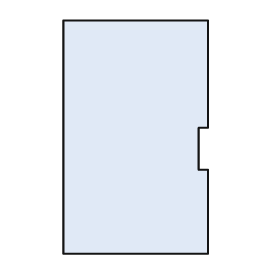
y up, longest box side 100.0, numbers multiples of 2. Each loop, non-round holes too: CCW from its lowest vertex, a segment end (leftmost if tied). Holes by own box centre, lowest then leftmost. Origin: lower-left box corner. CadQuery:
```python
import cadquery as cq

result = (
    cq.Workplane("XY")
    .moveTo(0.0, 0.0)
    .lineTo(62.0, 0.0)
    .lineTo(62.0, 36.0)
    .lineTo(58.0, 36.0)
    .lineTo(58.0, 54.0)
    .lineTo(62.0, 54.0)
    .lineTo(62.0, 100.0)
    .lineTo(0.0, 100.0)
    .close()
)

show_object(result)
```